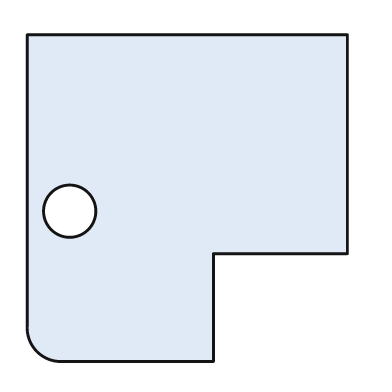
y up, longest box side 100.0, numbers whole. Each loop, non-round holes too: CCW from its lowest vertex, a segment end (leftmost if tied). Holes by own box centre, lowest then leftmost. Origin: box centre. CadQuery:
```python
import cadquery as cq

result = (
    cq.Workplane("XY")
    .moveTo(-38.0, -50.0)
    .lineTo(8.0, -50.0)
    .lineTo(8.0, -17.0)
    .lineTo(49.0, -17.0)
    .lineTo(49.0, 50.0)
    .lineTo(-49.0, 50.0)
    .lineTo(-49.0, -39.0)
    .threePointArc((-46.0, -47.0), (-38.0, -50.0))
    .close()
    .moveTo(-36.0, -4.0)
    .circle(8.0)
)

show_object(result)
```